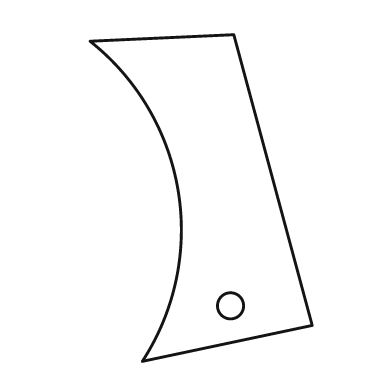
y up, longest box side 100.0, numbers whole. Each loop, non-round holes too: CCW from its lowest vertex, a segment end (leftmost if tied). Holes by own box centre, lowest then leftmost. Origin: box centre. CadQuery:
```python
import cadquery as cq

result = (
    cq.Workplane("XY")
    .moveTo(-18.0, -50.0)
    .lineTo(34.0, -39.0)
    .lineTo(10.0, 50.0)
    .lineTo(-34.0, 48.0)
    .threePointArc((-7.0, 2.0), (-18.0, -50.0))
    .close()
    .moveTo(9.0, -33.0)
    .circle(4.0)
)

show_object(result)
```